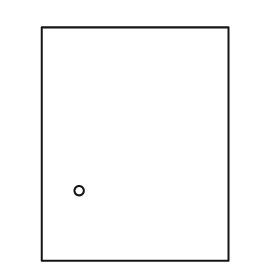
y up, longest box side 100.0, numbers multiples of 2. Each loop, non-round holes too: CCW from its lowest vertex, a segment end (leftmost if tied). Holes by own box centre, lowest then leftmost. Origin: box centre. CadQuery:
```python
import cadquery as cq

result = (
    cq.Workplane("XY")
    .moveTo(-40.0, -50.0)
    .lineTo(40.0, -50.0)
    .lineTo(40.0, 50.0)
    .lineTo(-40.0, 50.0)
    .close()
    .moveTo(-24.0, -20.0)
    .circle(2.0)
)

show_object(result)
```